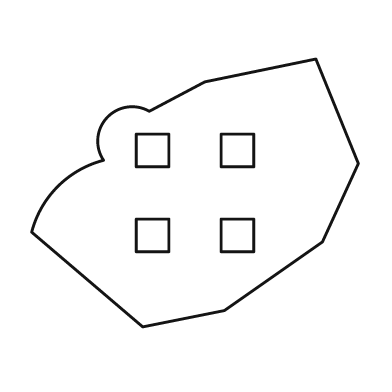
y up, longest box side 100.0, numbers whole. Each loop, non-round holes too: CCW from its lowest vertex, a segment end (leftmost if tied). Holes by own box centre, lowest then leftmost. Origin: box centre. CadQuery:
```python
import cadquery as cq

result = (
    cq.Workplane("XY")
    .moveTo(-16.0, -41.0)
    .lineTo(9.0, -36.0)
    .lineTo(39.0, -15.0)
    .lineTo(50.0, 9.0)
    .lineTo(37.0, 41.0)
    .lineTo(3.0, 34.0)
    .lineTo(-14.0, 25.0)
    .threePointArc((-27.0, 23.0), (-28.0, 10.0))
    .threePointArc((-42.0, 2.0), (-50.0, -12.0))
    .close()
    .moveTo(-18.0, -18.0)
    .lineTo(-8.0, -18.0)
    .lineTo(-8.0, -8.0)
    .lineTo(-18.0, -8.0)
    .close()
    .moveTo(8.0, -18.0)
    .lineTo(18.0, -18.0)
    .lineTo(18.0, -8.0)
    .lineTo(8.0, -8.0)
    .close()
    .moveTo(-18.0, 8.0)
    .lineTo(-8.0, 8.0)
    .lineTo(-8.0, 18.0)
    .lineTo(-18.0, 18.0)
    .close()
    .moveTo(8.0, 8.0)
    .lineTo(18.0, 8.0)
    .lineTo(18.0, 18.0)
    .lineTo(8.0, 18.0)
    .close()
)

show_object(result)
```